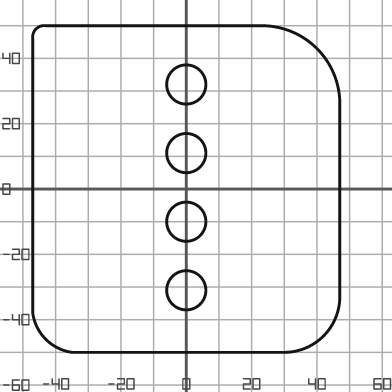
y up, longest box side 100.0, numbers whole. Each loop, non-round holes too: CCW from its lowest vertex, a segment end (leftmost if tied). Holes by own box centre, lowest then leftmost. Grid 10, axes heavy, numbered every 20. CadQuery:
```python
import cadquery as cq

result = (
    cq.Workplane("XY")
    .moveTo(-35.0, -50.0)
    .lineTo(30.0, -50.0)
    .threePointArc((42.0, -45.0), (47.0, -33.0))
    .lineTo(47.0, 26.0)
    .threePointArc((40.0, 43.0), (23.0, 50.0))
    .lineTo(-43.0, 50.0)
    .threePointArc((-46.0, 49.0), (-47.0, 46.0))
    .lineTo(-47.0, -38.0)
    .threePointArc((-43.0, -46.0), (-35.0, -50.0))
    .close()
    .moveTo(0.0, -31.0)
    .circle(6.0)
    .moveTo(0.0, -10.0)
    .circle(6.0)
    .moveTo(0.0, 11.0)
    .circle(6.0)
    .moveTo(0.0, 32.0)
    .circle(6.0)
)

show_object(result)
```